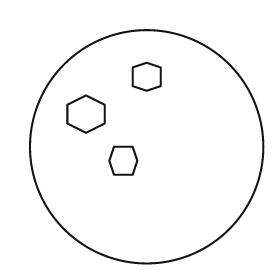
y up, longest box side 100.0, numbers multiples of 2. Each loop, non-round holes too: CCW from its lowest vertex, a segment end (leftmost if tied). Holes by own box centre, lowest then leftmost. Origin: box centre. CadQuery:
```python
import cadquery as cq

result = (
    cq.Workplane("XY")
    .moveTo(0.0, 0.0)
    .circle(50.0)
    .moveTo(-14.0, -12.0)
    .lineTo(-6.0, -12.0)
    .lineTo(-4.0, -6.0)
    .lineTo(-6.0, 0.0)
    .lineTo(-14.0, 0.0)
    .lineTo(-16.0, -6.0)
    .close()
    .moveTo(-26.0, 6.0)
    .lineTo(-18.0, 10.0)
    .lineTo(-18.0, 18.0)
    .lineTo(-26.0, 22.0)
    .lineTo(-34.0, 18.0)
    .lineTo(-34.0, 10.0)
    .close()
    .moveTo(0.0, 24.0)
    .lineTo(6.0, 26.0)
    .lineTo(6.0, 34.0)
    .lineTo(0.0, 36.0)
    .lineTo(-6.0, 34.0)
    .lineTo(-6.0, 26.0)
    .close()
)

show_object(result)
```